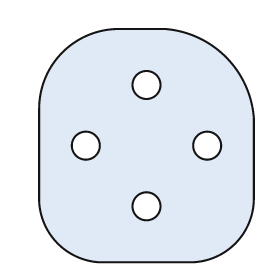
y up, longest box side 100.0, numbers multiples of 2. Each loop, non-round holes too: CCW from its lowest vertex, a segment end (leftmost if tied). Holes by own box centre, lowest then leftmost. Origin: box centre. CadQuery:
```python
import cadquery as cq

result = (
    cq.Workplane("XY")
    .moveTo(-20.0, -50.0)
    .lineTo(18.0, -50.0)
    .threePointArc((38.0, -42.0), (46.0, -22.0))
    .lineTo(46.0, 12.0)
    .threePointArc((34.0, 38.0), (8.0, 50.0))
    .lineTo(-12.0, 50.0)
    .threePointArc((-36.0, 40.0), (-46.0, 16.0))
    .lineTo(-46.0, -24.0)
    .threePointArc((-38.0, -42.0), (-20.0, -50.0))
    .close()
    .moveTo(0.0, -26.0)
    .circle(6.0)
    .moveTo(-26.0, 0.0)
    .circle(6.0)
    .moveTo(26.0, 0.0)
    .circle(6.0)
    .moveTo(0.0, 26.0)
    .circle(6.0)
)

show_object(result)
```